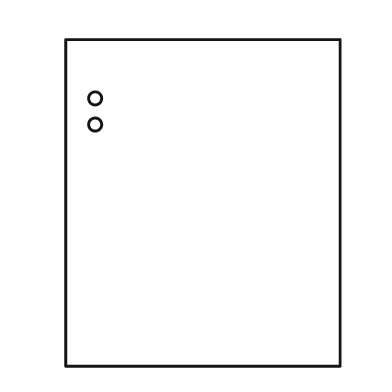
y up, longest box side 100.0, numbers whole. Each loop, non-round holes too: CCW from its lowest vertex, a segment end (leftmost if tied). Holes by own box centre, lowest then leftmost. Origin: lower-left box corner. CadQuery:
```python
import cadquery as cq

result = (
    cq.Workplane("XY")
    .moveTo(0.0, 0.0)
    .lineTo(84.0, 0.0)
    .lineTo(84.0, 100.0)
    .lineTo(0.0, 100.0)
    .close()
    .moveTo(9.0, 74.0)
    .circle(2.0)
    .moveTo(9.0, 82.0)
    .circle(2.0)
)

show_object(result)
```